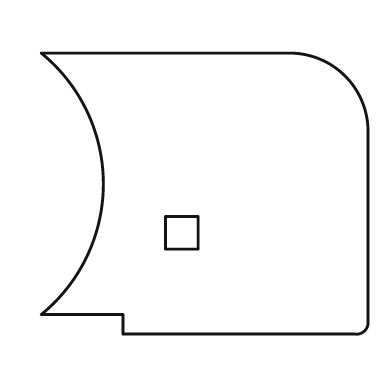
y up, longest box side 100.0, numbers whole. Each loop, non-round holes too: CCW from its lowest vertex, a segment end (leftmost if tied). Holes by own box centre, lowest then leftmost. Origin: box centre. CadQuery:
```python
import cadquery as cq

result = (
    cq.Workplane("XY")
    .moveTo(-25.0, -43.0)
    .lineTo(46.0, -43.0)
    .threePointArc((49.0, -42.0), (50.0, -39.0))
    .lineTo(50.0, 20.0)
    .threePointArc((43.0, 36.0), (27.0, 43.0))
    .lineTo(-50.0, 43.0)
    .threePointArc((-31.0, 3.0), (-50.0, -37.0))
    .lineTo(-25.0, -37.0)
    .close()
    .moveTo(-12.0, -17.0)
    .lineTo(-2.0, -17.0)
    .lineTo(-2.0, -7.0)
    .lineTo(-12.0, -7.0)
    .close()
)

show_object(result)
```